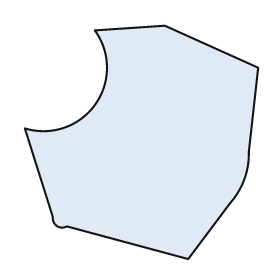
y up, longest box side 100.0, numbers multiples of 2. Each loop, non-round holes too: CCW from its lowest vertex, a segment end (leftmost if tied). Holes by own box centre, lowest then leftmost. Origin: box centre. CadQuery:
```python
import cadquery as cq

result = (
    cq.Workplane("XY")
    .moveTo(20.0, -50.0)
    .lineTo(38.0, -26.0)
    .threePointArc((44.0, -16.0), (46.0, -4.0))
    .lineTo(50.0, 32.0)
    .lineTo(10.0, 50.0)
    .lineTo(-20.0, 48.0)
    .threePointArc((-20.0, 16.0), (-50.0, 6.0))
    .lineTo(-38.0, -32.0)
    .threePointArc((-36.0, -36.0), (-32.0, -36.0))
    .close()
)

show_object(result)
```